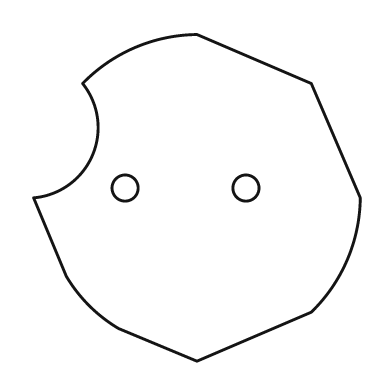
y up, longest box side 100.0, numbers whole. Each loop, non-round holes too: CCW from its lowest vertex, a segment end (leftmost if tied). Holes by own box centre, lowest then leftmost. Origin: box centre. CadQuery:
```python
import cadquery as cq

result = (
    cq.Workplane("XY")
    .moveTo(0.0, -50.0)
    .lineTo(35.0, -35.0)
    .threePointArc((46.0, -19.0), (50.0, 0.0))
    .lineTo(35.0, 35.0)
    .lineTo(0.0, 50.0)
    .threePointArc((-19.0, 46.0), (-35.0, 35.0))
    .threePointArc((-32.0, 13.0), (-50.0, 0.0))
    .lineTo(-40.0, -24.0)
    .threePointArc((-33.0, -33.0), (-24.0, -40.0))
    .close()
    .moveTo(-22.0, 3.0)
    .circle(4.0)
    .moveTo(15.0, 3.0)
    .circle(4.0)
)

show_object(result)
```